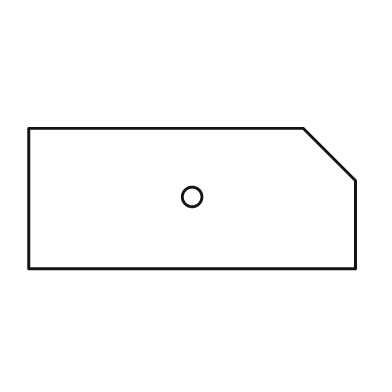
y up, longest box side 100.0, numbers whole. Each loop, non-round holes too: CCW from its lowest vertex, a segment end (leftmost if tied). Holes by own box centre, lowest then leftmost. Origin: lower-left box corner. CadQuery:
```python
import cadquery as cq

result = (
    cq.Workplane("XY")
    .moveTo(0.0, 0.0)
    .lineTo(100.0, 0.0)
    .lineTo(100.0, 27.0)
    .lineTo(84.0, 43.0)
    .lineTo(0.0, 43.0)
    .close()
    .moveTo(50.0, 22.0)
    .circle(3.0)
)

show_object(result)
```